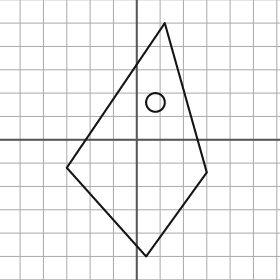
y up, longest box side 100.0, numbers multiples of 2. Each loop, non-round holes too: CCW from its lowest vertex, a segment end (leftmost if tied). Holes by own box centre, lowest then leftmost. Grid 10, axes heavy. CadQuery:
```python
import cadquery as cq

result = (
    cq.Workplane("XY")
    .moveTo(4.0, -50.0)
    .lineTo(30.0, -14.0)
    .lineTo(12.0, 50.0)
    .lineTo(-30.0, -12.0)
    .close()
    .moveTo(8.0, 16.0)
    .circle(4.0)
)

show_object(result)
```